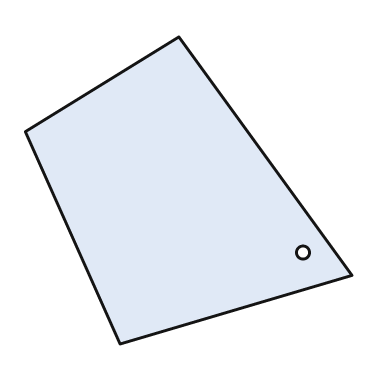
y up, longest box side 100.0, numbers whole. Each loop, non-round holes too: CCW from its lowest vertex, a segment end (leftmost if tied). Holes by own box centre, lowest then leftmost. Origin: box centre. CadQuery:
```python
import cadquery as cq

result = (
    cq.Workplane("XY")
    .moveTo(-21.0, -47.0)
    .lineTo(50.0, -26.0)
    .lineTo(-3.0, 47.0)
    .lineTo(-50.0, 18.0)
    .close()
    .moveTo(35.0, -19.0)
    .circle(2.0)
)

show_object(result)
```